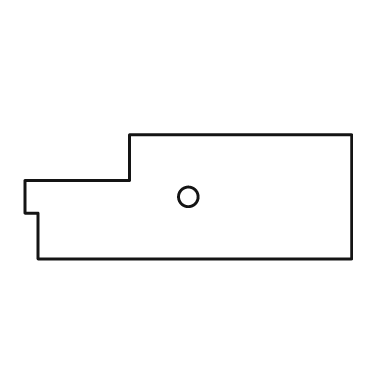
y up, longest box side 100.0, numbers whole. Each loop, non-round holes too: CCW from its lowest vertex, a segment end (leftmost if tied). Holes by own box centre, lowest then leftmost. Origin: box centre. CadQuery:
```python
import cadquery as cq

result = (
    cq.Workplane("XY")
    .moveTo(-46.0, -19.0)
    .lineTo(50.0, -19.0)
    .lineTo(50.0, 19.0)
    .lineTo(-18.0, 19.0)
    .lineTo(-18.0, 5.0)
    .lineTo(-50.0, 5.0)
    .lineTo(-50.0, -5.0)
    .lineTo(-46.0, -5.0)
    .close()
    .moveTo(0.0, 0.0)
    .circle(3.0)
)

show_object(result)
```